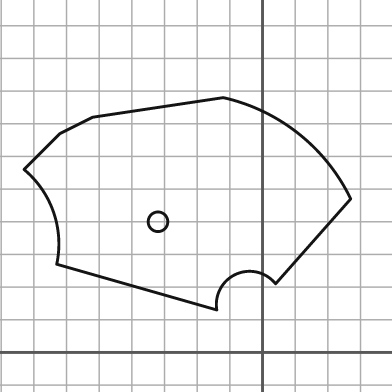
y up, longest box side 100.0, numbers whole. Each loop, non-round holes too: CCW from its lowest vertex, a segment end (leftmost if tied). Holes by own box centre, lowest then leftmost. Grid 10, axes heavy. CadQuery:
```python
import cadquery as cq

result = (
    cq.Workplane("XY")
    .moveTo(-14.0, 13.0)
    .threePointArc((-8.0, 24.0), (4.0, 21.0))
    .lineTo(27.0, 47.0)
    .threePointArc((11.0, 67.0), (-12.0, 78.0))
    .lineTo(-52.0, 72.0)
    .lineTo(-62.0, 67.0)
    .lineTo(-73.0, 56.0)
    .threePointArc((-64.0, 43.0), (-63.0, 27.0))
    .close()
    .moveTo(-32.0, 40.0)
    .circle(3.0)
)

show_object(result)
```